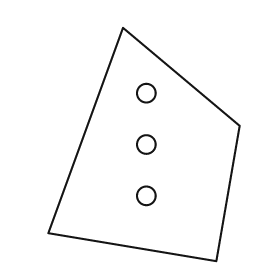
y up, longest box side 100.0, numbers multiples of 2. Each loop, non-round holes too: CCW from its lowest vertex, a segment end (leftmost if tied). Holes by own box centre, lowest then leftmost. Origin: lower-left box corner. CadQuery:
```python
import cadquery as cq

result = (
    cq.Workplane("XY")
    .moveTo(72.0, 0.0)
    .lineTo(82.0, 58.0)
    .lineTo(32.0, 100.0)
    .lineTo(0.0, 12.0)
    .close()
    .moveTo(42.0, 28.0)
    .circle(4.0)
    .moveTo(42.0, 50.0)
    .circle(4.0)
    .moveTo(42.0, 72.0)
    .circle(4.0)
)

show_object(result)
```